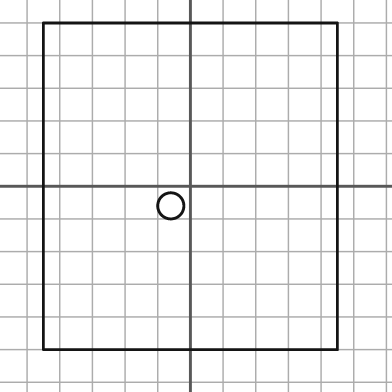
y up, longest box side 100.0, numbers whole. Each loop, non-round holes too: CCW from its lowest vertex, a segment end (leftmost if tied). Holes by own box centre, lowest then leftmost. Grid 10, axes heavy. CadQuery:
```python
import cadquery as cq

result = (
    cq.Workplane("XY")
    .moveTo(-45.0, -50.0)
    .lineTo(45.0, -50.0)
    .lineTo(45.0, 50.0)
    .lineTo(-45.0, 50.0)
    .close()
    .moveTo(-6.0, -6.0)
    .circle(4.0)
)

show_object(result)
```